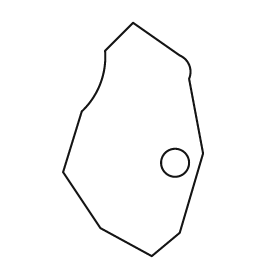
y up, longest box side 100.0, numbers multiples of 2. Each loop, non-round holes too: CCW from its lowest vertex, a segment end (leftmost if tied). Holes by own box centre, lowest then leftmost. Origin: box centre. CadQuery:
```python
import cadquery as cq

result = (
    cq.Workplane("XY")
    .moveTo(8.0, -50.0)
    .lineTo(20.0, -40.0)
    .lineTo(30.0, -6.0)
    .lineTo(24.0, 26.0)
    .threePointArc((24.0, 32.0), (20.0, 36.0))
    .lineTo(0.0, 50.0)
    .lineTo(-12.0, 38.0)
    .threePointArc((-14.0, 24.0), (-22.0, 12.0))
    .lineTo(-30.0, -14.0)
    .lineTo(-14.0, -38.0)
    .close()
    .moveTo(18.0, -10.0)
    .circle(6.0)
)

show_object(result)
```